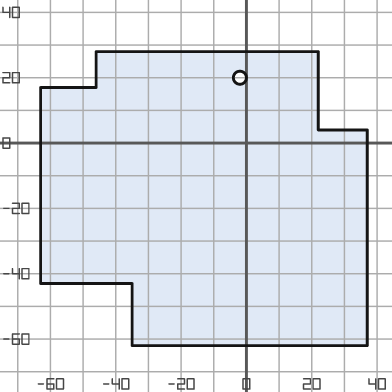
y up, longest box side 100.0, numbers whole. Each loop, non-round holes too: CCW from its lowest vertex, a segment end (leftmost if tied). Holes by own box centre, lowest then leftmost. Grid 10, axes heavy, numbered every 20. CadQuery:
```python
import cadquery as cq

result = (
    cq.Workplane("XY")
    .moveTo(-35.0, -62.0)
    .lineTo(37.0, -62.0)
    .lineTo(37.0, 4.0)
    .lineTo(22.0, 4.0)
    .lineTo(22.0, 28.0)
    .lineTo(-46.0, 28.0)
    .lineTo(-46.0, 17.0)
    .lineTo(-63.0, 17.0)
    .lineTo(-63.0, -43.0)
    .lineTo(-35.0, -43.0)
    .close()
    .moveTo(-2.0, 20.0)
    .circle(2.0)
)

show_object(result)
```